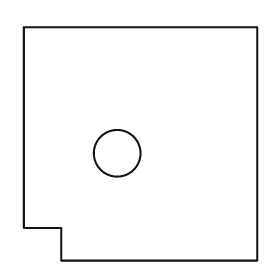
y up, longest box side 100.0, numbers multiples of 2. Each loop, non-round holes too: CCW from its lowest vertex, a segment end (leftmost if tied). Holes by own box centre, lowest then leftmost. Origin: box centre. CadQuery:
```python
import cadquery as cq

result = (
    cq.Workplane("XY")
    .moveTo(-34.0, -50.0)
    .lineTo(50.0, -50.0)
    .lineTo(50.0, 50.0)
    .lineTo(-50.0, 50.0)
    .lineTo(-50.0, -36.0)
    .lineTo(-34.0, -36.0)
    .close()
    .moveTo(-10.0, -4.0)
    .circle(10.0)
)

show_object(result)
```